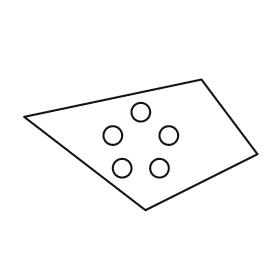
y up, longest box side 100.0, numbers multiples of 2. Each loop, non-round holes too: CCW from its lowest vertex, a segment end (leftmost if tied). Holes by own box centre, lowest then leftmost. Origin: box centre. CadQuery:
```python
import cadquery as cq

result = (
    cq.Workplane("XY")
    .moveTo(2.0, -28.0)
    .lineTo(50.0, -4.0)
    .lineTo(26.0, 28.0)
    .lineTo(-50.0, 12.0)
    .close()
    .moveTo(-8.0, -10.0)
    .circle(4.0)
    .moveTo(8.0, -10.0)
    .circle(4.0)
    .moveTo(-12.0, 4.0)
    .circle(4.0)
    .moveTo(12.0, 4.0)
    .circle(4.0)
    .moveTo(0.0, 14.0)
    .circle(4.0)
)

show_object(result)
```